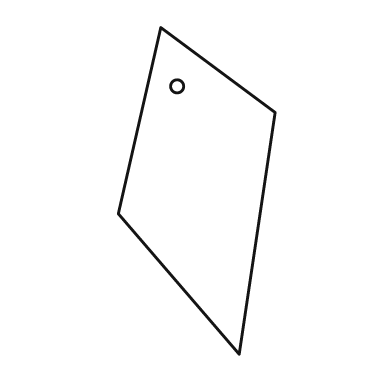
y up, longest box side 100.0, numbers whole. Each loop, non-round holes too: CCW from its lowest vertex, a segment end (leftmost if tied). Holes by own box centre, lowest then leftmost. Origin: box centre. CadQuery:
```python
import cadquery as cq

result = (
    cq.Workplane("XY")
    .moveTo(13.0, -50.0)
    .lineTo(24.0, 24.0)
    .lineTo(-11.0, 50.0)
    .lineTo(-24.0, -7.0)
    .close()
    .moveTo(-6.0, 32.0)
    .circle(2.0)
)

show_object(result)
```